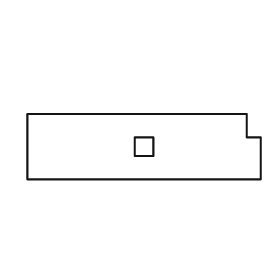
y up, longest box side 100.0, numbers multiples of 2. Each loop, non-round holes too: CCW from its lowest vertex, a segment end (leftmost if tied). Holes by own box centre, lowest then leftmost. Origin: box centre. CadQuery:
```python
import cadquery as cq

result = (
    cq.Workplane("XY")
    .moveTo(-50.0, -14.0)
    .lineTo(50.0, -14.0)
    .lineTo(50.0, 4.0)
    .lineTo(44.0, 4.0)
    .lineTo(44.0, 14.0)
    .lineTo(-50.0, 14.0)
    .close()
    .moveTo(-4.0, -4.0)
    .lineTo(4.0, -4.0)
    .lineTo(4.0, 4.0)
    .lineTo(-4.0, 4.0)
    .close()
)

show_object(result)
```